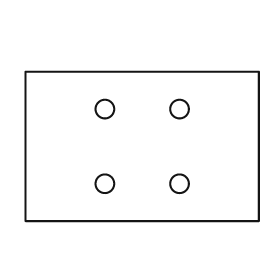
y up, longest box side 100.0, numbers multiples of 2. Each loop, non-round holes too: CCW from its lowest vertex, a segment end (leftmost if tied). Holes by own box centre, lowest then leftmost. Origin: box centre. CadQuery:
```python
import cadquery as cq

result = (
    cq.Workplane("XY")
    .moveTo(-50.0, -32.0)
    .lineTo(50.0, -32.0)
    .lineTo(50.0, 32.0)
    .lineTo(-50.0, 32.0)
    .close()
    .moveTo(-16.0, -16.0)
    .circle(4.0)
    .moveTo(16.0, -16.0)
    .circle(4.0)
    .moveTo(-16.0, 16.0)
    .circle(4.0)
    .moveTo(16.0, 16.0)
    .circle(4.0)
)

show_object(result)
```